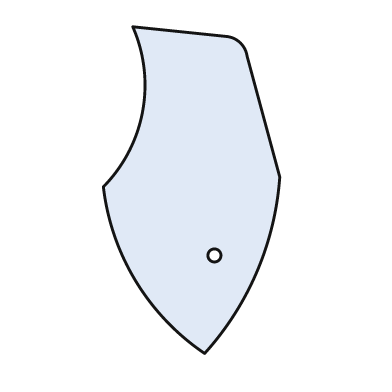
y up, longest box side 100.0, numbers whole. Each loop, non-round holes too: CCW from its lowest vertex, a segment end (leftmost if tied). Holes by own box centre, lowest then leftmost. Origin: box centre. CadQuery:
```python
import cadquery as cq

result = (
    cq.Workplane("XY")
    .moveTo(4.0, -50.0)
    .threePointArc((20.0, -25.0), (27.0, 4.0))
    .lineTo(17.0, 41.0)
    .threePointArc((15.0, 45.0), (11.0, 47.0))
    .lineTo(-18.0, 50.0)
    .threePointArc((-15.0, 24.0), (-27.0, 1.0))
    .threePointArc((-17.0, -28.0), (4.0, -50.0))
    .close()
    .moveTo(7.0, -20.0)
    .circle(2.0)
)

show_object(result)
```